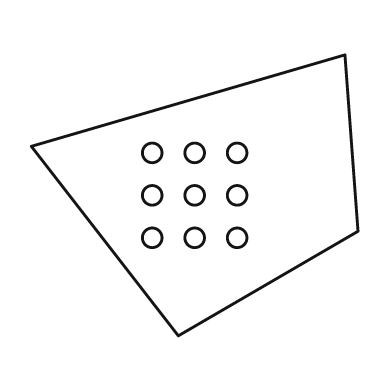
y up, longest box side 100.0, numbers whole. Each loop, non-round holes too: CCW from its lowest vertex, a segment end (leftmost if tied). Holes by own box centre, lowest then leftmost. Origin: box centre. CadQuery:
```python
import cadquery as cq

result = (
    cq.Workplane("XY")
    .moveTo(-5.0, -43.0)
    .lineTo(50.0, -11.0)
    .lineTo(46.0, 43.0)
    .lineTo(-50.0, 15.0)
    .close()
    .moveTo(-13.0, -13.0)
    .circle(3.0)
    .moveTo(0.0, -13.0)
    .circle(3.0)
    .moveTo(13.0, -13.0)
    .circle(3.0)
    .moveTo(-13.0, 0.0)
    .circle(3.0)
    .moveTo(0.0, 0.0)
    .circle(3.0)
    .moveTo(13.0, 0.0)
    .circle(3.0)
    .moveTo(-13.0, 13.0)
    .circle(3.0)
    .moveTo(0.0, 13.0)
    .circle(3.0)
    .moveTo(13.0, 13.0)
    .circle(3.0)
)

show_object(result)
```